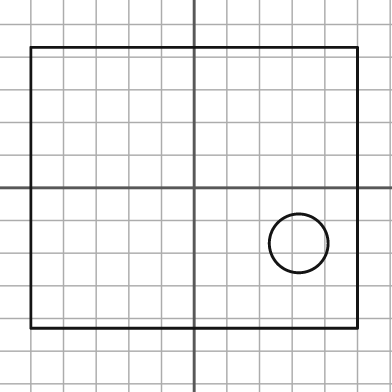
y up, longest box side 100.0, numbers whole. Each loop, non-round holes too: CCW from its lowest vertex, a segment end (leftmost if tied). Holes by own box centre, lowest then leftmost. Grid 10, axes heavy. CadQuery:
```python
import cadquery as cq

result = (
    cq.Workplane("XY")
    .moveTo(-50.0, -43.0)
    .lineTo(50.0, -43.0)
    .lineTo(50.0, 43.0)
    .lineTo(-50.0, 43.0)
    .close()
    .moveTo(32.0, -17.0)
    .circle(9.0)
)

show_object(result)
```